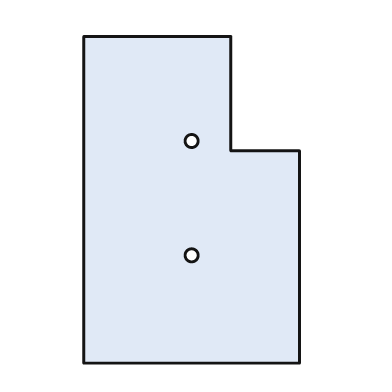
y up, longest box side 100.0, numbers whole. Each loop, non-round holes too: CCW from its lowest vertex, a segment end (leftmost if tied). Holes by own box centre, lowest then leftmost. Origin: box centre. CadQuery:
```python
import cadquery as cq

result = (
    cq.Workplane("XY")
    .moveTo(-33.0, -50.0)
    .lineTo(33.0, -50.0)
    .lineTo(33.0, 15.0)
    .lineTo(12.0, 15.0)
    .lineTo(12.0, 50.0)
    .lineTo(-33.0, 50.0)
    .close()
    .moveTo(0.0, -17.0)
    .circle(2.0)
    .moveTo(0.0, 18.0)
    .circle(2.0)
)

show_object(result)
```